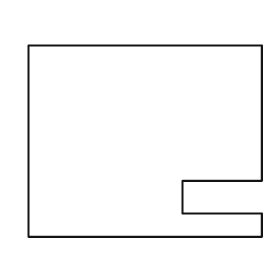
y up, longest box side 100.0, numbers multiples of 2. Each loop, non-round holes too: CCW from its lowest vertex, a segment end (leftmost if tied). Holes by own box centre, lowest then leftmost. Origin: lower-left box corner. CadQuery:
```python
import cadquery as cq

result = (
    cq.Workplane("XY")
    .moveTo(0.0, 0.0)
    .lineTo(100.0, 0.0)
    .lineTo(100.0, 10.0)
    .lineTo(66.0, 10.0)
    .lineTo(66.0, 24.0)
    .lineTo(100.0, 24.0)
    .lineTo(100.0, 82.0)
    .lineTo(0.0, 82.0)
    .close()
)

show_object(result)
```